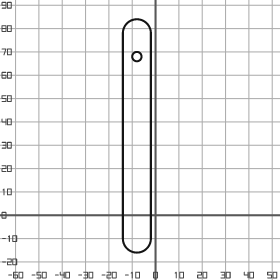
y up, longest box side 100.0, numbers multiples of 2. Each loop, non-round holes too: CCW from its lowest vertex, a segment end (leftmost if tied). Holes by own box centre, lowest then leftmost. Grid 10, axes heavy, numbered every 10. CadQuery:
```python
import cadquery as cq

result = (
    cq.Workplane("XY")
    .moveTo(-14.0, -10.0)
    .threePointArc((-8.0, -16.0), (-2.0, -10.0))
    .lineTo(-2.0, 78.0)
    .threePointArc((-8.0, 84.0), (-14.0, 78.0))
    .close()
    .moveTo(-8.0, 68.0)
    .circle(2.0)
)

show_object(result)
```